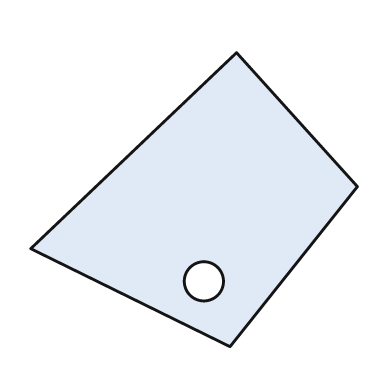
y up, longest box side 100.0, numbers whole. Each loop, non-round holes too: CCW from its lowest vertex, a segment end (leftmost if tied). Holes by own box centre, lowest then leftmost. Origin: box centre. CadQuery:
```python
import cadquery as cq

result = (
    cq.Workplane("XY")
    .moveTo(11.0, -45.0)
    .lineTo(50.0, 4.0)
    .lineTo(13.0, 45.0)
    .lineTo(-50.0, -15.0)
    .close()
    .moveTo(3.0, -25.0)
    .circle(6.0)
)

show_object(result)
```